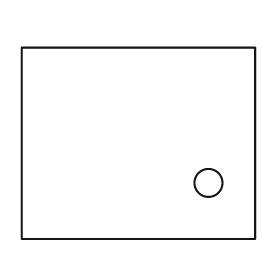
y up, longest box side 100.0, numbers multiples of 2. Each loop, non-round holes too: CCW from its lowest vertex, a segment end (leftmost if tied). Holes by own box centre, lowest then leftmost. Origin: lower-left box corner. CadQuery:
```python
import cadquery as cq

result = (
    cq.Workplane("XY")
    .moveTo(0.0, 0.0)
    .lineTo(100.0, 0.0)
    .lineTo(100.0, 82.0)
    .lineTo(0.0, 82.0)
    .close()
    .moveTo(80.0, 24.0)
    .circle(6.0)
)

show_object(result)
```